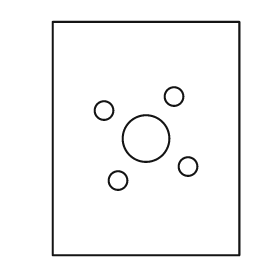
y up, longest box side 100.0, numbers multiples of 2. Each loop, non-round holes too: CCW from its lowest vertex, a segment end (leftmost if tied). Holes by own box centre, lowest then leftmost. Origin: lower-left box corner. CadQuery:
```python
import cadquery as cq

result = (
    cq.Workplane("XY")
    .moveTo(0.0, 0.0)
    .lineTo(80.0, 0.0)
    .lineTo(80.0, 100.0)
    .lineTo(0.0, 100.0)
    .close()
    .moveTo(28.0, 32.0)
    .circle(4.0)
    .moveTo(58.0, 38.0)
    .circle(4.0)
    .moveTo(40.0, 50.0)
    .circle(10.0)
    .moveTo(22.0, 62.0)
    .circle(4.0)
    .moveTo(52.0, 68.0)
    .circle(4.0)
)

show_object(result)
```